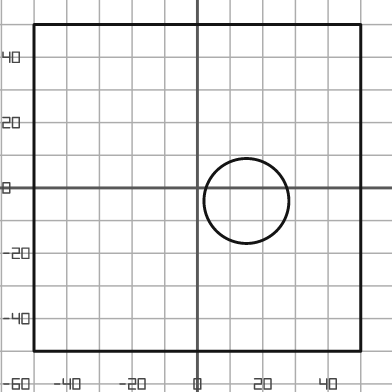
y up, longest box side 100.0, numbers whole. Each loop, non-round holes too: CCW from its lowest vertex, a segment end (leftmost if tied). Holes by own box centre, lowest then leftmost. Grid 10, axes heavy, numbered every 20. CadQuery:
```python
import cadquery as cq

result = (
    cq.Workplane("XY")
    .moveTo(-50.0, -50.0)
    .lineTo(50.0, -50.0)
    .lineTo(50.0, 50.0)
    .lineTo(-50.0, 50.0)
    .close()
    .moveTo(15.0, -4.0)
    .circle(13.0)
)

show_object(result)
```